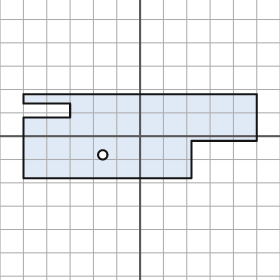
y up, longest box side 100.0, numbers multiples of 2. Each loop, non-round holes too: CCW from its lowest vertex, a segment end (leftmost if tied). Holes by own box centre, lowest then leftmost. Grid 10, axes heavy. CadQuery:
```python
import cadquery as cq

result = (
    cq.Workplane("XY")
    .moveTo(-50.0, -18.0)
    .lineTo(22.0, -18.0)
    .lineTo(22.0, -2.0)
    .lineTo(50.0, -2.0)
    .lineTo(50.0, 18.0)
    .lineTo(-50.0, 18.0)
    .lineTo(-50.0, 14.0)
    .lineTo(-30.0, 14.0)
    .lineTo(-30.0, 8.0)
    .lineTo(-50.0, 8.0)
    .close()
    .moveTo(-16.0, -8.0)
    .circle(2.0)
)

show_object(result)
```